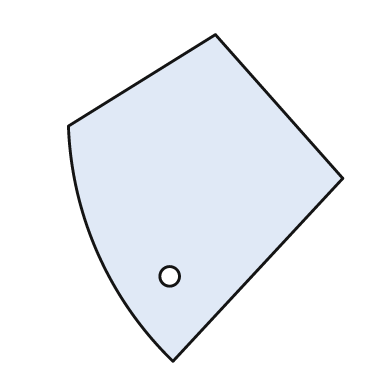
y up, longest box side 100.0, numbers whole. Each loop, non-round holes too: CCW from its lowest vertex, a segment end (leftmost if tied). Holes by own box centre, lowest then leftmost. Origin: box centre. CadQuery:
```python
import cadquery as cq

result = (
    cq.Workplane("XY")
    .moveTo(-10.0, -50.0)
    .lineTo(42.0, 6.0)
    .lineTo(3.0, 50.0)
    .lineTo(-42.0, 22.0)
    .threePointArc((-33.0, -17.0), (-10.0, -50.0))
    .close()
    .moveTo(-11.0, -24.0)
    .circle(3.0)
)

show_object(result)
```